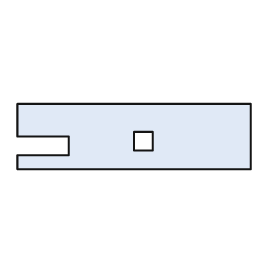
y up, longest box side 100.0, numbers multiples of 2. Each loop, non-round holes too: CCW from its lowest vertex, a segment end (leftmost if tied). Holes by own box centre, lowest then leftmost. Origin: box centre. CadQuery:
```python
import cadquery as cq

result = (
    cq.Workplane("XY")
    .moveTo(-50.0, -14.0)
    .lineTo(50.0, -14.0)
    .lineTo(50.0, 14.0)
    .lineTo(-50.0, 14.0)
    .lineTo(-50.0, 0.0)
    .lineTo(-28.0, 0.0)
    .lineTo(-28.0, -8.0)
    .lineTo(-50.0, -8.0)
    .close()
    .moveTo(0.0, -6.0)
    .lineTo(8.0, -6.0)
    .lineTo(8.0, 2.0)
    .lineTo(0.0, 2.0)
    .close()
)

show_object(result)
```